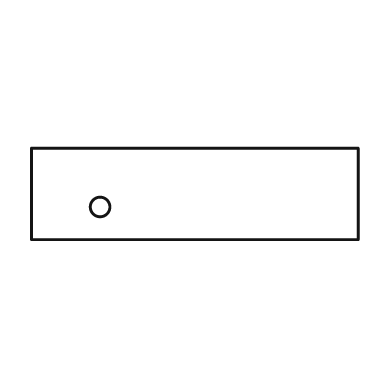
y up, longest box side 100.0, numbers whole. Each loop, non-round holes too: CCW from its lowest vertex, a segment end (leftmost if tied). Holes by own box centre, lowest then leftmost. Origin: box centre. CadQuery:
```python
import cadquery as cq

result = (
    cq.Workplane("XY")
    .moveTo(-50.0, -14.0)
    .lineTo(50.0, -14.0)
    .lineTo(50.0, 14.0)
    .lineTo(-50.0, 14.0)
    .close()
    .moveTo(-29.0, -4.0)
    .circle(3.0)
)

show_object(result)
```